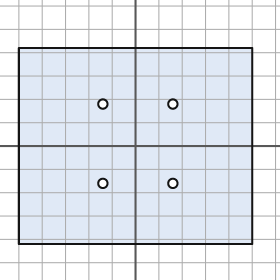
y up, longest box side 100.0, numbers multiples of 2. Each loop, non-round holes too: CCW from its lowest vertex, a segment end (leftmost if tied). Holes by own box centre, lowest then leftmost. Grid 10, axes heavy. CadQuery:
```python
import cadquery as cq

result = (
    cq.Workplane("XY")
    .moveTo(-50.0, -42.0)
    .lineTo(50.0, -42.0)
    .lineTo(50.0, 42.0)
    .lineTo(-50.0, 42.0)
    .close()
    .moveTo(-14.0, -16.0)
    .circle(2.0)
    .moveTo(16.0, -16.0)
    .circle(2.0)
    .moveTo(-14.0, 18.0)
    .circle(2.0)
    .moveTo(16.0, 18.0)
    .circle(2.0)
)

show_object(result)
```